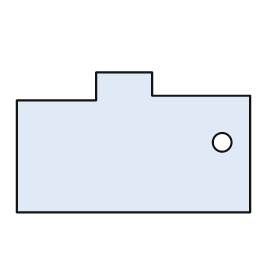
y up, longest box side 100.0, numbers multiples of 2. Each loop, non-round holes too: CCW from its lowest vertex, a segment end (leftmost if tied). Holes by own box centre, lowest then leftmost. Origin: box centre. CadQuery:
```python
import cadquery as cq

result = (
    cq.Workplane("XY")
    .moveTo(-50.0, -30.0)
    .lineTo(50.0, -30.0)
    .lineTo(50.0, 20.0)
    .lineTo(8.0, 20.0)
    .lineTo(8.0, 30.0)
    .lineTo(-16.0, 30.0)
    .lineTo(-16.0, 18.0)
    .lineTo(-50.0, 18.0)
    .close()
    .moveTo(38.0, 0.0)
    .circle(4.0)
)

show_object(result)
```